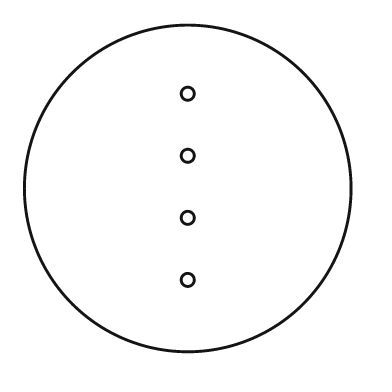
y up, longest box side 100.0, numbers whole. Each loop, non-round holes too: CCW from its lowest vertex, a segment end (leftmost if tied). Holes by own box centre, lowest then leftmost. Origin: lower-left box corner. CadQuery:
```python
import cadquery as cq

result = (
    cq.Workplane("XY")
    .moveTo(50.0, 50.0)
    .circle(50.0)
    .moveTo(50.0, 22.0)
    .circle(2.0)
    .moveTo(50.0, 41.0)
    .circle(2.0)
    .moveTo(50.0, 60.0)
    .circle(2.0)
    .moveTo(50.0, 79.0)
    .circle(2.0)
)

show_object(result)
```